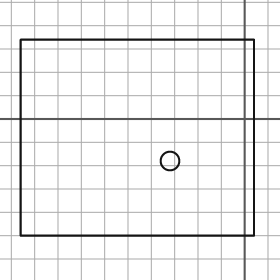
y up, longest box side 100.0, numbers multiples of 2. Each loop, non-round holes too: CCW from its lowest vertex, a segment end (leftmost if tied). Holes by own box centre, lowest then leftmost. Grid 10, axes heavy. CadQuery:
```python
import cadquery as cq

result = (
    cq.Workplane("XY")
    .moveTo(-96.0, -50.0)
    .lineTo(4.0, -50.0)
    .lineTo(4.0, 34.0)
    .lineTo(-96.0, 34.0)
    .close()
    .moveTo(-32.0, -18.0)
    .circle(4.0)
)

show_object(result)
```